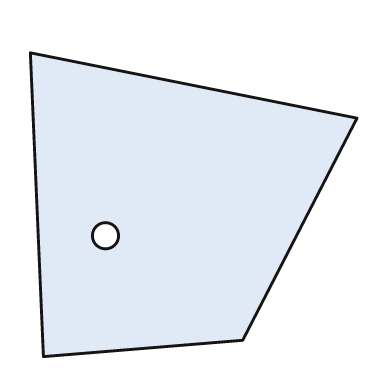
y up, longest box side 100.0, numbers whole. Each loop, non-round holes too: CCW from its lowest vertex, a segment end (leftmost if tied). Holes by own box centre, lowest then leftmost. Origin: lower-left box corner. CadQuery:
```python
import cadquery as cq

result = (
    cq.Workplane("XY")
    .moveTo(4.0, 0.0)
    .lineTo(65.0, 5.0)
    .lineTo(100.0, 73.0)
    .lineTo(0.0, 93.0)
    .close()
    .moveTo(23.0, 37.0)
    .circle(4.0)
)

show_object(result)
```